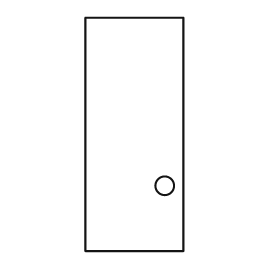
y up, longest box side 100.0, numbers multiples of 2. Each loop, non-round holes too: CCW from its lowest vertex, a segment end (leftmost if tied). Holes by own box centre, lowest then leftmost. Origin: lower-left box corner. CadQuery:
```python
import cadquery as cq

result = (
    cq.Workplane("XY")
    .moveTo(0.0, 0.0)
    .lineTo(42.0, 0.0)
    .lineTo(42.0, 100.0)
    .lineTo(0.0, 100.0)
    .close()
    .moveTo(34.0, 28.0)
    .circle(4.0)
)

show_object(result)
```